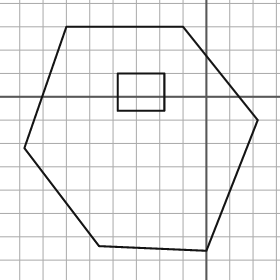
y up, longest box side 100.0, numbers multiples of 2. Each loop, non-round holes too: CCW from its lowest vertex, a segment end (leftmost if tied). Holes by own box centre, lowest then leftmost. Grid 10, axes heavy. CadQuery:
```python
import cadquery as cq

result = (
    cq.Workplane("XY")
    .moveTo(0.0, -66.0)
    .lineTo(22.0, -10.0)
    .lineTo(-10.0, 30.0)
    .lineTo(-60.0, 30.0)
    .lineTo(-78.0, -22.0)
    .lineTo(-46.0, -64.0)
    .close()
    .moveTo(-38.0, -6.0)
    .lineTo(-18.0, -6.0)
    .lineTo(-18.0, 10.0)
    .lineTo(-38.0, 10.0)
    .close()
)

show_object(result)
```